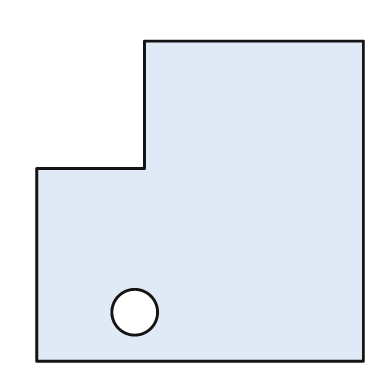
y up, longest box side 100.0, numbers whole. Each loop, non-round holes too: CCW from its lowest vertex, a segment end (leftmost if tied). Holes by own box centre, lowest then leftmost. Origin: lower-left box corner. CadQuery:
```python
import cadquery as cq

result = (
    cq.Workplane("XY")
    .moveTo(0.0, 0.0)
    .lineTo(100.0, 0.0)
    .lineTo(100.0, 98.0)
    .lineTo(33.0, 98.0)
    .lineTo(33.0, 59.0)
    .lineTo(0.0, 59.0)
    .close()
    .moveTo(30.0, 15.0)
    .circle(7.0)
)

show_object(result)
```